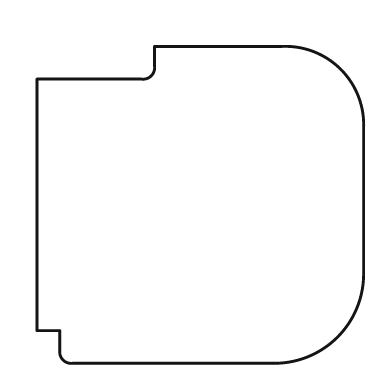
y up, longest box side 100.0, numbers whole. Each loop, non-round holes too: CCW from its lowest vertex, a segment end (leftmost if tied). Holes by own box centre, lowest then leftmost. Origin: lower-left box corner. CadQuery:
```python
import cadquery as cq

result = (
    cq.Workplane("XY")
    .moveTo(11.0, 0.0)
    .lineTo(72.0, 0.0)
    .threePointArc((92.0, 8.0), (100.0, 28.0))
    .lineTo(100.0, 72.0)
    .threePointArc((93.0, 90.0), (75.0, 97.0))
    .lineTo(36.0, 97.0)
    .lineTo(36.0, 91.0)
    .threePointArc((35.0, 88.0), (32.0, 87.0))
    .lineTo(0.0, 87.0)
    .lineTo(0.0, 10.0)
    .lineTo(7.0, 10.0)
    .lineTo(7.0, 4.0)
    .threePointArc((8.0, 1.0), (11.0, 0.0))
    .close()
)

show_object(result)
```